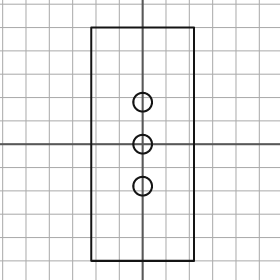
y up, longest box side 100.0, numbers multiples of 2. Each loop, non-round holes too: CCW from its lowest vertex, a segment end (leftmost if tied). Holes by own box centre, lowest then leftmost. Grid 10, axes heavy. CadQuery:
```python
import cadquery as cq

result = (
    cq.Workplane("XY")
    .moveTo(-22.0, -50.0)
    .lineTo(22.0, -50.0)
    .lineTo(22.0, 50.0)
    .lineTo(-22.0, 50.0)
    .close()
    .moveTo(0.0, -18.0)
    .circle(4.0)
    .moveTo(0.0, 0.0)
    .circle(4.0)
    .moveTo(0.0, 18.0)
    .circle(4.0)
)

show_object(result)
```